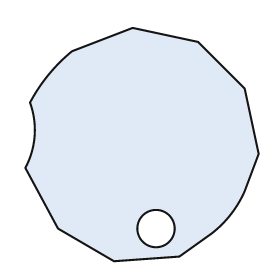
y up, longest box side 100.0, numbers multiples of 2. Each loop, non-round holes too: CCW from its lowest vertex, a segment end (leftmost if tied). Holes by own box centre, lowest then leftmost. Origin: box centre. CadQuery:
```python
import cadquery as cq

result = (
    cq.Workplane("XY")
    .moveTo(-12.0, -50.0)
    .lineTo(16.0, -48.0)
    .lineTo(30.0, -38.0)
    .threePointArc((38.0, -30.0), (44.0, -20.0))
    .lineTo(50.0, -4.0)
    .lineTo(44.0, 24.0)
    .lineTo(24.0, 44.0)
    .lineTo(-4.0, 50.0)
    .lineTo(-30.0, 40.0)
    .threePointArc((-40.0, 30.0), (-48.0, 18.0))
    .threePointArc((-46.0, 4.0), (-50.0, -10.0))
    .lineTo(-36.0, -36.0)
    .close()
    .moveTo(6.0, -36.0)
    .circle(8.0)
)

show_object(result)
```